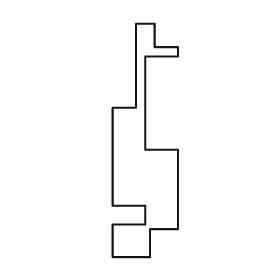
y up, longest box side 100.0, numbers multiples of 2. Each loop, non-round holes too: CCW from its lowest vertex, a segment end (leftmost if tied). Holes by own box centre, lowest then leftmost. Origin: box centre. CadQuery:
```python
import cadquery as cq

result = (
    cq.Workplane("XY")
    .moveTo(-14.0, -50.0)
    .lineTo(2.0, -50.0)
    .lineTo(2.0, -38.0)
    .lineTo(14.0, -38.0)
    .lineTo(14.0, -4.0)
    .lineTo(0.0, -4.0)
    .lineTo(0.0, 36.0)
    .lineTo(14.0, 36.0)
    .lineTo(14.0, 40.0)
    .lineTo(4.0, 40.0)
    .lineTo(4.0, 50.0)
    .lineTo(-4.0, 50.0)
    .lineTo(-4.0, 14.0)
    .lineTo(-14.0, 14.0)
    .lineTo(-14.0, -28.0)
    .lineTo(0.0, -28.0)
    .lineTo(0.0, -36.0)
    .lineTo(-14.0, -36.0)
    .close()
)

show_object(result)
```